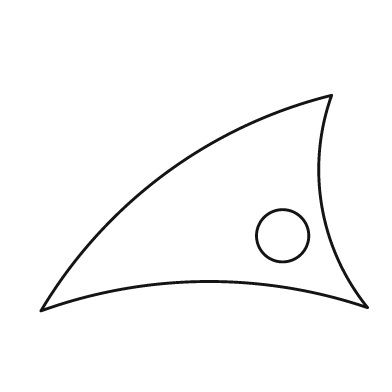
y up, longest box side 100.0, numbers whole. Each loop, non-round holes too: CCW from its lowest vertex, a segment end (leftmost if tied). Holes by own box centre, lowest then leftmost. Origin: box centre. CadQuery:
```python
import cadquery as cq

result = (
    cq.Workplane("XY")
    .moveTo(-50.0, -33.0)
    .threePointArc((0.0, -24.0), (50.0, -32.0))
    .threePointArc((36.0, -1.0), (39.0, 33.0))
    .threePointArc((-12.0, 9.0), (-50.0, -33.0))
    .close()
    .moveTo(24.0, -10.0)
    .circle(8.0)
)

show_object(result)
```